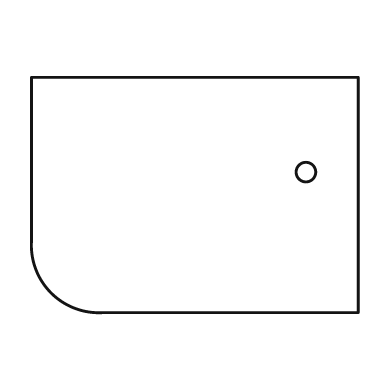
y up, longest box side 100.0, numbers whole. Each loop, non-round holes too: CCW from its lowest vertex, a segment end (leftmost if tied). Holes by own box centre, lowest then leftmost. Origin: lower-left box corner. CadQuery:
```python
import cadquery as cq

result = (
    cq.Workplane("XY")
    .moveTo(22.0, 0.0)
    .lineTo(100.0, 0.0)
    .lineTo(100.0, 72.0)
    .lineTo(0.0, 72.0)
    .lineTo(0.0, 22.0)
    .threePointArc((6.0, 6.0), (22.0, 0.0))
    .close()
    .moveTo(84.0, 43.0)
    .circle(3.0)
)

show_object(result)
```